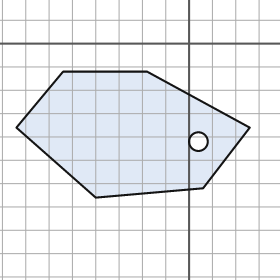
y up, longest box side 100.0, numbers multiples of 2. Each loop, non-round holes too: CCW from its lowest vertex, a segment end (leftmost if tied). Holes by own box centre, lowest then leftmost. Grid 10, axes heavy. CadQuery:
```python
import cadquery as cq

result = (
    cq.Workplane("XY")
    .moveTo(-40.0, -66.0)
    .lineTo(6.0, -62.0)
    .lineTo(26.0, -36.0)
    .lineTo(-18.0, -12.0)
    .lineTo(-54.0, -12.0)
    .lineTo(-74.0, -36.0)
    .close()
    .moveTo(4.0, -42.0)
    .circle(4.0)
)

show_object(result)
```